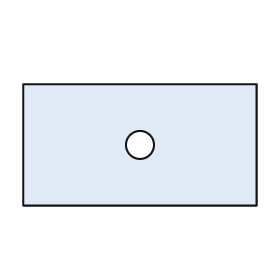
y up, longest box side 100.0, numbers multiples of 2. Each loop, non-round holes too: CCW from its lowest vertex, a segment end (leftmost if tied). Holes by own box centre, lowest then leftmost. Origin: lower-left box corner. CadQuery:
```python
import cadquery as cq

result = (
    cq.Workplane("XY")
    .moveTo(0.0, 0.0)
    .lineTo(100.0, 0.0)
    .lineTo(100.0, 52.0)
    .lineTo(0.0, 52.0)
    .close()
    .moveTo(50.0, 26.0)
    .circle(6.0)
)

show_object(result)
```